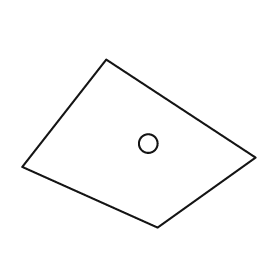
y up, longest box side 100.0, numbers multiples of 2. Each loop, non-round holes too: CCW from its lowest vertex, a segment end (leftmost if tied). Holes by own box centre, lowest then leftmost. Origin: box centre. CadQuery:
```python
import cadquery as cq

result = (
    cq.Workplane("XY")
    .moveTo(8.0, -36.0)
    .lineTo(50.0, -6.0)
    .lineTo(-14.0, 36.0)
    .lineTo(-50.0, -10.0)
    .close()
    .moveTo(4.0, 0.0)
    .circle(4.0)
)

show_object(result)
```